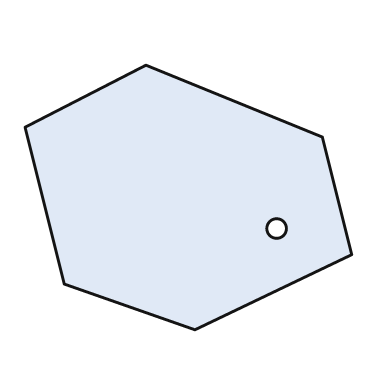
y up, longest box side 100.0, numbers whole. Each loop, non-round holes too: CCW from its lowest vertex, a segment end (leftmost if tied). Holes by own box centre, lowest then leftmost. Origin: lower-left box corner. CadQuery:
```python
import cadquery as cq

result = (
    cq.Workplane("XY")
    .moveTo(52.0, 0.0)
    .lineTo(100.0, 23.0)
    .lineTo(91.0, 59.0)
    .lineTo(37.0, 81.0)
    .lineTo(0.0, 62.0)
    .lineTo(12.0, 14.0)
    .close()
    .moveTo(77.0, 31.0)
    .circle(3.0)
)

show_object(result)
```